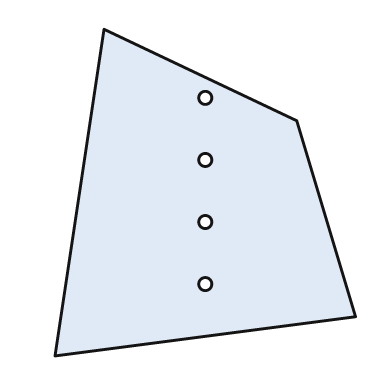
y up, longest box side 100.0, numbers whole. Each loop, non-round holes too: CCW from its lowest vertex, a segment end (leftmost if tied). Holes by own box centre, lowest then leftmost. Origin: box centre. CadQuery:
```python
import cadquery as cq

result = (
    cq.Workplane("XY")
    .moveTo(-46.0, -50.0)
    .lineTo(46.0, -38.0)
    .lineTo(28.0, 22.0)
    .lineTo(-31.0, 50.0)
    .close()
    .moveTo(0.0, -28.0)
    .circle(2.0)
    .moveTo(0.0, -9.0)
    .circle(2.0)
    .moveTo(0.0, 10.0)
    .circle(2.0)
    .moveTo(0.0, 29.0)
    .circle(2.0)
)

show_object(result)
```